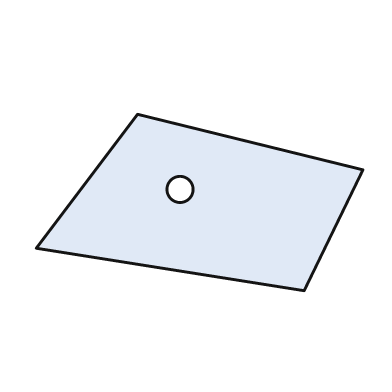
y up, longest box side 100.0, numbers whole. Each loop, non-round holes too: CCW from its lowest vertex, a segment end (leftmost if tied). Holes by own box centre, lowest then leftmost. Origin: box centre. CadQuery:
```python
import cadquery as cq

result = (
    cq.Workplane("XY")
    .moveTo(32.0, -27.0)
    .lineTo(50.0, 10.0)
    .lineTo(-19.0, 27.0)
    .lineTo(-50.0, -14.0)
    .close()
    .moveTo(-6.0, 4.0)
    .circle(4.0)
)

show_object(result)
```